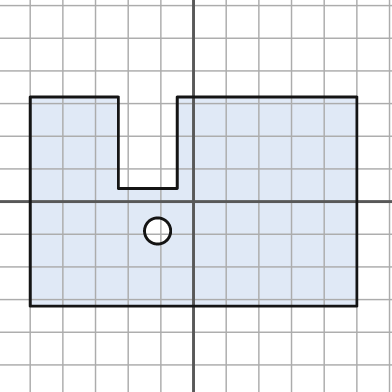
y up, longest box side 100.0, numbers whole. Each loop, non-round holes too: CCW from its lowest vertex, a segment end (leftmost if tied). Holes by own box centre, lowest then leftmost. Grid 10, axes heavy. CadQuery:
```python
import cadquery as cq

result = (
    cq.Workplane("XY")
    .moveTo(-50.0, -32.0)
    .lineTo(50.0, -32.0)
    .lineTo(50.0, 32.0)
    .lineTo(-5.0, 32.0)
    .lineTo(-5.0, 4.0)
    .lineTo(-23.0, 4.0)
    .lineTo(-23.0, 32.0)
    .lineTo(-50.0, 32.0)
    .close()
    .moveTo(-11.0, -9.0)
    .circle(4.0)
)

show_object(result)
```